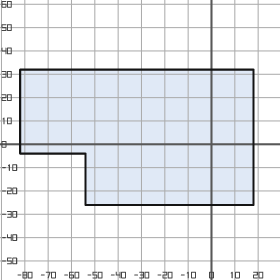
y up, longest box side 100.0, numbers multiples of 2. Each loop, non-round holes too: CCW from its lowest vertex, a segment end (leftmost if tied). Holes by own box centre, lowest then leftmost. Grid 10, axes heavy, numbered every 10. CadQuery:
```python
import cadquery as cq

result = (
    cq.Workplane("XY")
    .moveTo(-54.0, -26.0)
    .lineTo(18.0, -26.0)
    .lineTo(18.0, 32.0)
    .lineTo(-82.0, 32.0)
    .lineTo(-82.0, -4.0)
    .lineTo(-54.0, -4.0)
    .close()
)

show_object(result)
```